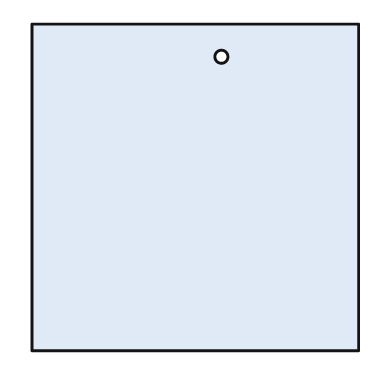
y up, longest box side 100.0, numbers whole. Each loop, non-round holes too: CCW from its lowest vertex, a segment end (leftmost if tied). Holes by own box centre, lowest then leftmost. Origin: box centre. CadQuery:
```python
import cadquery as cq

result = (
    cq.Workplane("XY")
    .moveTo(-50.0, -50.0)
    .lineTo(50.0, -50.0)
    .lineTo(50.0, 50.0)
    .lineTo(-50.0, 50.0)
    .close()
    .moveTo(8.0, 40.0)
    .circle(2.0)
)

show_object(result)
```